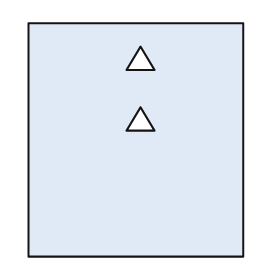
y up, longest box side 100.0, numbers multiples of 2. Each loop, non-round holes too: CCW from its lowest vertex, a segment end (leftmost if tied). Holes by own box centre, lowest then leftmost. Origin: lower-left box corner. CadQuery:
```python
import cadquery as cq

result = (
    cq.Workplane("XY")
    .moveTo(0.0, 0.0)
    .lineTo(92.0, 0.0)
    .lineTo(92.0, 100.0)
    .lineTo(0.0, 100.0)
    .close()
    .moveTo(42.0, 54.0)
    .lineTo(54.0, 54.0)
    .lineTo(48.0, 64.0)
    .close()
    .moveTo(42.0, 80.0)
    .lineTo(54.0, 80.0)
    .lineTo(48.0, 90.0)
    .close()
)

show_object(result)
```